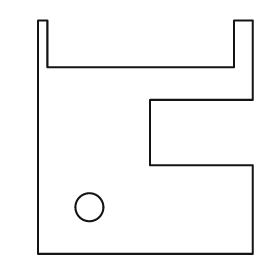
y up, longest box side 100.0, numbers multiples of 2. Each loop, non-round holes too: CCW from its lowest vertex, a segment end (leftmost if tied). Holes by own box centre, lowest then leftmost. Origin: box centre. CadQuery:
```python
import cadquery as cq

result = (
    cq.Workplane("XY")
    .moveTo(-46.0, -50.0)
    .lineTo(46.0, -50.0)
    .lineTo(46.0, -12.0)
    .lineTo(2.0, -12.0)
    .lineTo(2.0, 16.0)
    .lineTo(46.0, 16.0)
    .lineTo(46.0, 50.0)
    .lineTo(38.0, 50.0)
    .lineTo(38.0, 30.0)
    .lineTo(-42.0, 30.0)
    .lineTo(-42.0, 50.0)
    .lineTo(-46.0, 50.0)
    .close()
    .moveTo(-24.0, -30.0)
    .circle(6.0)
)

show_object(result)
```